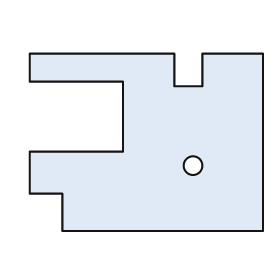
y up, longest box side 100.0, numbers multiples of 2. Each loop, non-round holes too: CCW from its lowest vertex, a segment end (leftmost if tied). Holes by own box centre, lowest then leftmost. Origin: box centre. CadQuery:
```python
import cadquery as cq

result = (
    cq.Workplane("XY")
    .moveTo(-36.0, -38.0)
    .lineTo(50.0, -38.0)
    .lineTo(50.0, 38.0)
    .lineTo(24.0, 38.0)
    .lineTo(24.0, 24.0)
    .lineTo(12.0, 24.0)
    .lineTo(12.0, 38.0)
    .lineTo(-50.0, 38.0)
    .lineTo(-50.0, 26.0)
    .lineTo(-10.0, 26.0)
    .lineTo(-10.0, -4.0)
    .lineTo(-50.0, -4.0)
    .lineTo(-50.0, -22.0)
    .lineTo(-36.0, -22.0)
    .close()
    .moveTo(20.0, -10.0)
    .circle(4.0)
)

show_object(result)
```